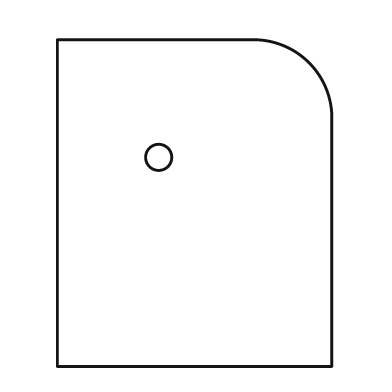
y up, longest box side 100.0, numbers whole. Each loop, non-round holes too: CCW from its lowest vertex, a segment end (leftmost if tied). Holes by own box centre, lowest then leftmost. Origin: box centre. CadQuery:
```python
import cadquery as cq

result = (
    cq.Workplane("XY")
    .moveTo(-42.0, -50.0)
    .lineTo(42.0, -50.0)
    .lineTo(42.0, 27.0)
    .threePointArc((35.0, 43.0), (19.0, 50.0))
    .lineTo(-42.0, 50.0)
    .close()
    .moveTo(-11.0, 14.0)
    .circle(4.0)
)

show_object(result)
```